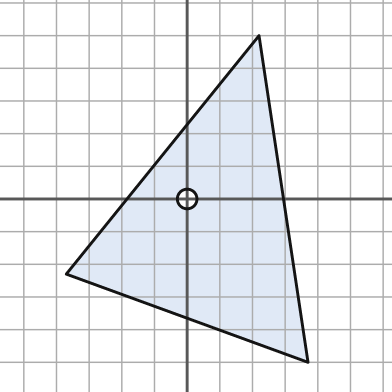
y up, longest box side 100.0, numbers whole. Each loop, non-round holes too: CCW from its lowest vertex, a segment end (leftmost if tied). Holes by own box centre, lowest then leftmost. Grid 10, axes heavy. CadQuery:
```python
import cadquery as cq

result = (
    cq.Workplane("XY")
    .moveTo(37.0, -50.0)
    .lineTo(22.0, 50.0)
    .lineTo(-37.0, -23.0)
    .close()
    .moveTo(0.0, 0.0)
    .circle(3.0)
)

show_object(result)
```